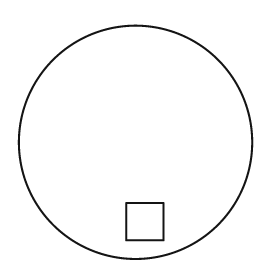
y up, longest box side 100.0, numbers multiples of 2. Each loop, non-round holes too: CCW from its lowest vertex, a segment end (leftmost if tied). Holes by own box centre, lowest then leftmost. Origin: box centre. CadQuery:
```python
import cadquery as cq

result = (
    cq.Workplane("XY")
    .moveTo(0.0, 0.0)
    .circle(50.0)
    .moveTo(-4.0, -42.0)
    .lineTo(12.0, -42.0)
    .lineTo(12.0, -26.0)
    .lineTo(-4.0, -26.0)
    .close()
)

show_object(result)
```